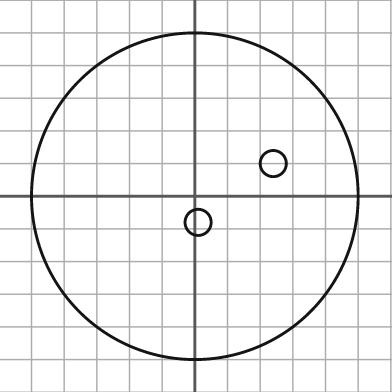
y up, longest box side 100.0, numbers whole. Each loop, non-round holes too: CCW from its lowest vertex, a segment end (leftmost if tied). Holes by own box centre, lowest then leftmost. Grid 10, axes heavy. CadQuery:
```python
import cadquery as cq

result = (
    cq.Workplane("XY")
    .moveTo(0.0, 0.0)
    .circle(50.0)
    .moveTo(1.0, -8.0)
    .circle(4.0)
    .moveTo(24.0, 10.0)
    .circle(4.0)
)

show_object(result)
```